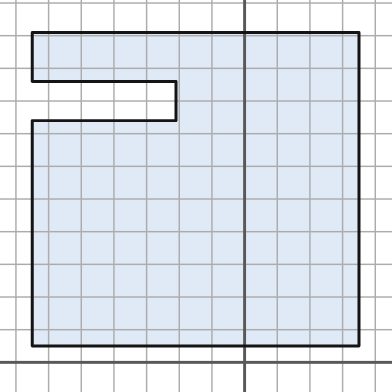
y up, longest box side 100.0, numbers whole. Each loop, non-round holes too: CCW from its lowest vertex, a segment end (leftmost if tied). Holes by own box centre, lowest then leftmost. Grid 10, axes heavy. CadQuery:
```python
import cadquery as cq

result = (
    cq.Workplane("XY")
    .moveTo(-65.0, 5.0)
    .lineTo(35.0, 5.0)
    .lineTo(35.0, 101.0)
    .lineTo(-65.0, 101.0)
    .lineTo(-65.0, 86.0)
    .lineTo(-21.0, 86.0)
    .lineTo(-21.0, 74.0)
    .lineTo(-65.0, 74.0)
    .close()
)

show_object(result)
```